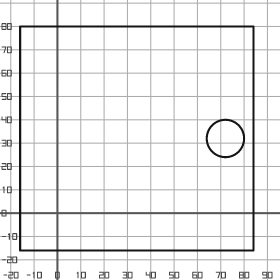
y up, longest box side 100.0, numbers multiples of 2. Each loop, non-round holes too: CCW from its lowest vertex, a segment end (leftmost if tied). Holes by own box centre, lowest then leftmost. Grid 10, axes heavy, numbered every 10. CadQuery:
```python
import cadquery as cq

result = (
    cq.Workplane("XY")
    .moveTo(-16.0, -16.0)
    .lineTo(84.0, -16.0)
    .lineTo(84.0, 80.0)
    .lineTo(-16.0, 80.0)
    .close()
    .moveTo(72.0, 32.0)
    .circle(8.0)
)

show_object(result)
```